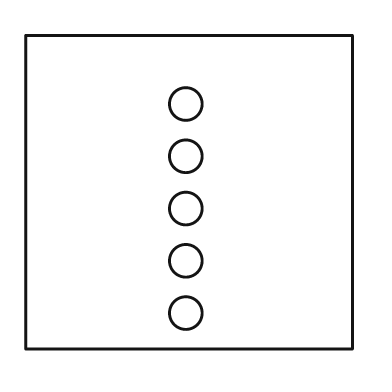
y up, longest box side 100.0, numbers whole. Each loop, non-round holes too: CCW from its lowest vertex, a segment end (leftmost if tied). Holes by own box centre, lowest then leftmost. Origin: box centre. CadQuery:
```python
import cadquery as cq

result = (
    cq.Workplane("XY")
    .moveTo(-50.0, -48.0)
    .lineTo(50.0, -48.0)
    .lineTo(50.0, 48.0)
    .lineTo(-50.0, 48.0)
    .close()
    .moveTo(-1.0, -37.0)
    .circle(5.0)
    .moveTo(-1.0, -21.0)
    .circle(5.0)
    .moveTo(-1.0, -5.0)
    .circle(5.0)
    .moveTo(-1.0, 11.0)
    .circle(5.0)
    .moveTo(-1.0, 27.0)
    .circle(5.0)
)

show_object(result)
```